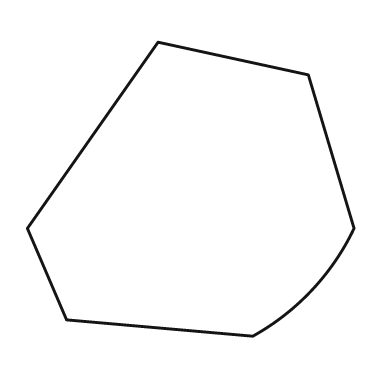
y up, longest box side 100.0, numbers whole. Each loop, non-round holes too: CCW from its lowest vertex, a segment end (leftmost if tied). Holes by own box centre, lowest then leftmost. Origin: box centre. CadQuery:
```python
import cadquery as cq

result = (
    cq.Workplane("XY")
    .moveTo(19.0, -45.0)
    .threePointArc((37.0, -31.0), (50.0, -12.0))
    .lineTo(36.0, 35.0)
    .lineTo(-10.0, 45.0)
    .lineTo(-50.0, -12.0)
    .lineTo(-38.0, -40.0)
    .close()
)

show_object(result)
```